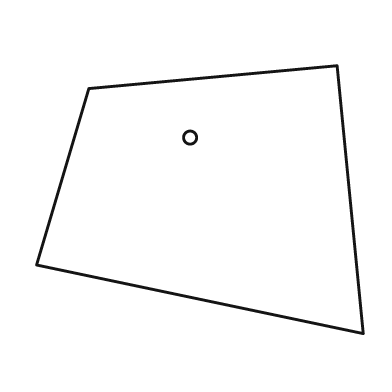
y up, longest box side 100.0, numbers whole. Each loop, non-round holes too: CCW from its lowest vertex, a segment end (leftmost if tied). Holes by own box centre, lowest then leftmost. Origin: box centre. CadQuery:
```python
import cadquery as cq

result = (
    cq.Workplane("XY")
    .moveTo(50.0, -41.0)
    .lineTo(42.0, 41.0)
    .lineTo(-34.0, 34.0)
    .lineTo(-50.0, -20.0)
    .close()
    .moveTo(-3.0, 19.0)
    .circle(2.0)
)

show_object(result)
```